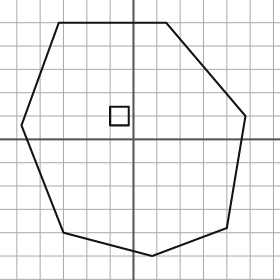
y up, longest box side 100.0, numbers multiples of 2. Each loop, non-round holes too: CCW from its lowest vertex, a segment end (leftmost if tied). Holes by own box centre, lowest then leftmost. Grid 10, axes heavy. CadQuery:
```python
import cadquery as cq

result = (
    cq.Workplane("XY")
    .moveTo(8.0, -50.0)
    .lineTo(40.0, -38.0)
    .lineTo(48.0, 10.0)
    .lineTo(14.0, 50.0)
    .lineTo(-32.0, 50.0)
    .lineTo(-48.0, 6.0)
    .lineTo(-30.0, -40.0)
    .close()
    .moveTo(-10.0, 6.0)
    .lineTo(-2.0, 6.0)
    .lineTo(-2.0, 14.0)
    .lineTo(-10.0, 14.0)
    .close()
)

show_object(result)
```